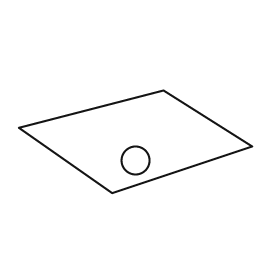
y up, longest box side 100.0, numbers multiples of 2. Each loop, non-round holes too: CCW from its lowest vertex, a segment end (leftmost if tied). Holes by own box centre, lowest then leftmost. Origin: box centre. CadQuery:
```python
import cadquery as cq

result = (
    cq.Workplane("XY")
    .moveTo(-10.0, -22.0)
    .lineTo(50.0, -2.0)
    .lineTo(12.0, 22.0)
    .lineTo(-50.0, 6.0)
    .close()
    .moveTo(0.0, -8.0)
    .circle(6.0)
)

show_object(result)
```